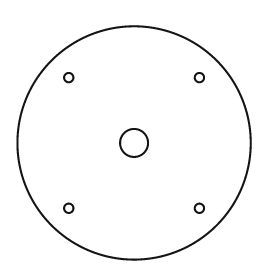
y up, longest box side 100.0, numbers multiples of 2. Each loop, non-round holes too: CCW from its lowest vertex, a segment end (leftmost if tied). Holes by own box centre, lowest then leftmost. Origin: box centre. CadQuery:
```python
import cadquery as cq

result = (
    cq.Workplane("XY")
    .moveTo(0.0, 0.0)
    .circle(50.0)
    .moveTo(-28.0, -28.0)
    .circle(2.0)
    .moveTo(28.0, -28.0)
    .circle(2.0)
    .moveTo(0.0, 0.0)
    .circle(6.0)
    .moveTo(-28.0, 28.0)
    .circle(2.0)
    .moveTo(28.0, 28.0)
    .circle(2.0)
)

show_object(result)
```